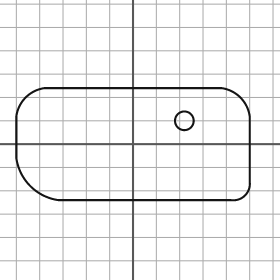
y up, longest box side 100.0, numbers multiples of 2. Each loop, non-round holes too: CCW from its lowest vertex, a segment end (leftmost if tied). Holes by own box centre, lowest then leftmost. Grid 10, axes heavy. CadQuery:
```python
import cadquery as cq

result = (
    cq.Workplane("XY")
    .moveTo(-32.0, -24.0)
    .lineTo(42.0, -24.0)
    .threePointArc((48.0, -22.0), (50.0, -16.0))
    .lineTo(50.0, 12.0)
    .threePointArc((46.0, 20.0), (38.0, 24.0))
    .lineTo(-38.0, 24.0)
    .threePointArc((-46.0, 20.0), (-50.0, 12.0))
    .lineTo(-50.0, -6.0)
    .threePointArc((-44.0, -18.0), (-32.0, -24.0))
    .close()
    .moveTo(22.0, 10.0)
    .circle(4.0)
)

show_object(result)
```